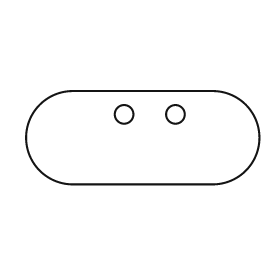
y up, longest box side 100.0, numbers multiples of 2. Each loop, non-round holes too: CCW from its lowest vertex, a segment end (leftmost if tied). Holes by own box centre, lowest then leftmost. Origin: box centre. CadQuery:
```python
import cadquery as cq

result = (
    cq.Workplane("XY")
    .moveTo(-30.0, -20.0)
    .lineTo(30.0, -20.0)
    .threePointArc((50.0, 0.0), (30.0, 20.0))
    .lineTo(-30.0, 20.0)
    .threePointArc((-50.0, 0.0), (-30.0, -20.0))
    .close()
    .moveTo(-8.0, 10.0)
    .circle(4.0)
    .moveTo(14.0, 10.0)
    .circle(4.0)
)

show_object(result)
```